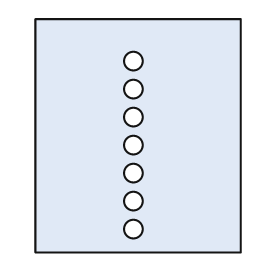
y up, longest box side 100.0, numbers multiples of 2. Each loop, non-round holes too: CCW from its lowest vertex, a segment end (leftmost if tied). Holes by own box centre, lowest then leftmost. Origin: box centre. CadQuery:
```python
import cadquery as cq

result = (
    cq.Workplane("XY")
    .moveTo(-44.0, -50.0)
    .lineTo(44.0, -50.0)
    .lineTo(44.0, 50.0)
    .lineTo(-44.0, 50.0)
    .close()
    .moveTo(-2.0, -40.0)
    .circle(4.0)
    .moveTo(-2.0, -28.0)
    .circle(4.0)
    .moveTo(-2.0, -16.0)
    .circle(4.0)
    .moveTo(-2.0, -4.0)
    .circle(4.0)
    .moveTo(-2.0, 8.0)
    .circle(4.0)
    .moveTo(-2.0, 20.0)
    .circle(4.0)
    .moveTo(-2.0, 32.0)
    .circle(4.0)
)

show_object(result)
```